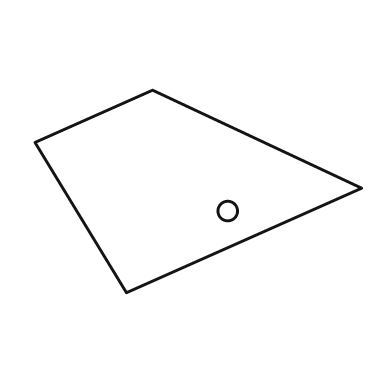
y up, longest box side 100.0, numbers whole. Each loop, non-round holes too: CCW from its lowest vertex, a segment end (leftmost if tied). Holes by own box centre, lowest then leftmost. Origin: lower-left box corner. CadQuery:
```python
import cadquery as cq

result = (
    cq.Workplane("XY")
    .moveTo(28.0, 0.0)
    .lineTo(100.0, 32.0)
    .lineTo(36.0, 62.0)
    .lineTo(0.0, 46.0)
    .close()
    .moveTo(59.0, 25.0)
    .circle(3.0)
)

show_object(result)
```